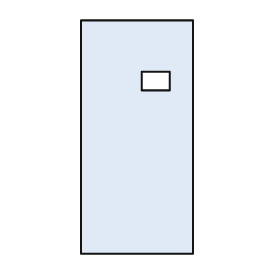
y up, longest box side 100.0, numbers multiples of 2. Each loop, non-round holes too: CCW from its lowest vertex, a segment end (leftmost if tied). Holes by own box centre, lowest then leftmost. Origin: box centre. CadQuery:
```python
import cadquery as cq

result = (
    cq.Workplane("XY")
    .moveTo(-24.0, -50.0)
    .lineTo(24.0, -50.0)
    .lineTo(24.0, 50.0)
    .lineTo(-24.0, 50.0)
    .close()
    .moveTo(2.0, 20.0)
    .lineTo(14.0, 20.0)
    .lineTo(14.0, 28.0)
    .lineTo(2.0, 28.0)
    .close()
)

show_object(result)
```